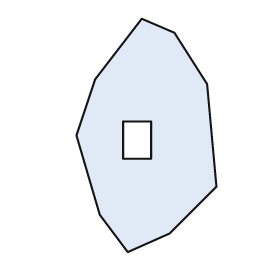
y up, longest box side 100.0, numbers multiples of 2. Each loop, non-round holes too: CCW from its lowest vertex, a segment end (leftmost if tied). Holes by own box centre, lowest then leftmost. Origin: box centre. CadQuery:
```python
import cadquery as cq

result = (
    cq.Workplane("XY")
    .moveTo(-8.0, -50.0)
    .lineTo(10.0, -42.0)
    .lineTo(30.0, -22.0)
    .lineTo(26.0, 22.0)
    .lineTo(12.0, 44.0)
    .lineTo(-2.0, 50.0)
    .lineTo(-22.0, 24.0)
    .lineTo(-30.0, 0.0)
    .lineTo(-20.0, -34.0)
    .close()
    .moveTo(-10.0, -10.0)
    .lineTo(2.0, -10.0)
    .lineTo(2.0, 6.0)
    .lineTo(-10.0, 6.0)
    .close()
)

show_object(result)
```